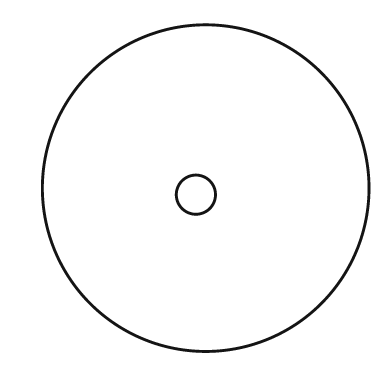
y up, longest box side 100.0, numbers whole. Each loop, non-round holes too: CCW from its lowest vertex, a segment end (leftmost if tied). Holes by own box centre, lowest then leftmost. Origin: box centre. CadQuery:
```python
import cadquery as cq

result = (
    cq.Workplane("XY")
    .moveTo(0.0, 0.0)
    .circle(50.0)
    .moveTo(-3.0, -2.0)
    .circle(6.0)
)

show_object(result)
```